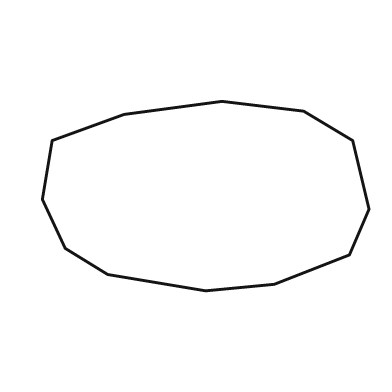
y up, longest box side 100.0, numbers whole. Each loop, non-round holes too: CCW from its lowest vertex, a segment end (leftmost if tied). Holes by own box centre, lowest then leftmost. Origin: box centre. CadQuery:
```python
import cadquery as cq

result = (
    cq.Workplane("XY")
    .moveTo(0.0, -29.0)
    .lineTo(21.0, -27.0)
    .lineTo(44.0, -18.0)
    .lineTo(50.0, -4.0)
    .lineTo(45.0, 17.0)
    .lineTo(30.0, 26.0)
    .lineTo(5.0, 29.0)
    .lineTo(-25.0, 25.0)
    .lineTo(-47.0, 17.0)
    .lineTo(-50.0, -1.0)
    .lineTo(-43.0, -16.0)
    .lineTo(-30.0, -24.0)
    .close()
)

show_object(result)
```